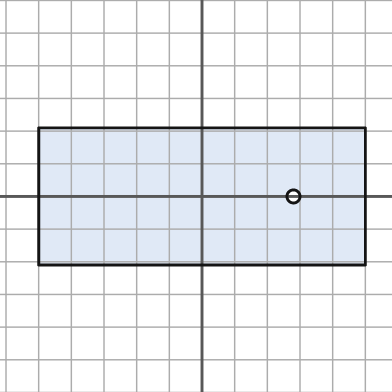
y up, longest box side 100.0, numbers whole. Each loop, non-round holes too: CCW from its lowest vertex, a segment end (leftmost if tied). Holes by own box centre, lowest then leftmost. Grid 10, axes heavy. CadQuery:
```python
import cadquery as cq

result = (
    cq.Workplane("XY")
    .moveTo(-50.0, -21.0)
    .lineTo(50.0, -21.0)
    .lineTo(50.0, 21.0)
    .lineTo(-50.0, 21.0)
    .close()
    .moveTo(28.0, 0.0)
    .circle(2.0)
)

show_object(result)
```